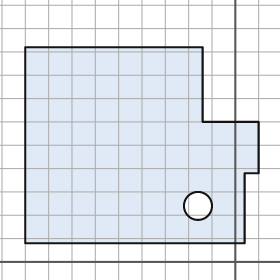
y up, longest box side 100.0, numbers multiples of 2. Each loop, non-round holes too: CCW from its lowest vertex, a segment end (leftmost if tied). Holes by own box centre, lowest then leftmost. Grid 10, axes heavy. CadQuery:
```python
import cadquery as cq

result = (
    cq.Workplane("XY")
    .moveTo(-90.0, 8.0)
    .lineTo(4.0, 8.0)
    .lineTo(4.0, 38.0)
    .lineTo(10.0, 38.0)
    .lineTo(10.0, 60.0)
    .lineTo(-14.0, 60.0)
    .lineTo(-14.0, 92.0)
    .lineTo(-90.0, 92.0)
    .close()
    .moveTo(-16.0, 24.0)
    .circle(6.0)
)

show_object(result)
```